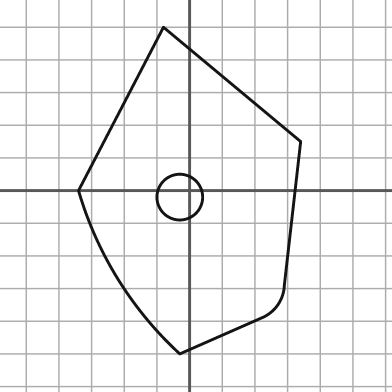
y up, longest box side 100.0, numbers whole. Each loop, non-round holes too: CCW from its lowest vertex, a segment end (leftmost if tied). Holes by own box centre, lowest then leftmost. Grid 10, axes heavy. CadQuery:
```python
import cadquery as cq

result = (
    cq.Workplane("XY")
    .moveTo(-3.0, -50.0)
    .lineTo(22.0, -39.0)
    .threePointArc((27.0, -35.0), (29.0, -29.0))
    .lineTo(34.0, 15.0)
    .lineTo(-8.0, 50.0)
    .lineTo(-34.0, 0.0)
    .threePointArc((-22.0, -27.0), (-3.0, -50.0))
    .close()
    .moveTo(-3.0, -2.0)
    .circle(7.0)
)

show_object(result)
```